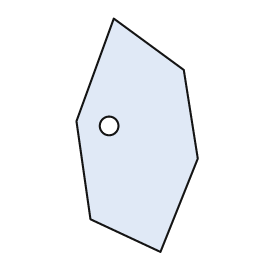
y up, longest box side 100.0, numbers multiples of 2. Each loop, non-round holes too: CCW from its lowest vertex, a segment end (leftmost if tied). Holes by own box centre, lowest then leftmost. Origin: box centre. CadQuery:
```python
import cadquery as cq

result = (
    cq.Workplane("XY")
    .moveTo(10.0, -50.0)
    .lineTo(26.0, -10.0)
    .lineTo(20.0, 28.0)
    .lineTo(-10.0, 50.0)
    .lineTo(-26.0, 6.0)
    .lineTo(-20.0, -36.0)
    .close()
    .moveTo(-12.0, 4.0)
    .circle(4.0)
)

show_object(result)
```